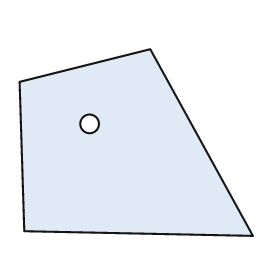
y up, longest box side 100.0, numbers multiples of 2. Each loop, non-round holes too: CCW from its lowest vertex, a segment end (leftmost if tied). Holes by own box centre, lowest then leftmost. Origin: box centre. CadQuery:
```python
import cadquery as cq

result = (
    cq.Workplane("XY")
    .moveTo(50.0, -40.0)
    .lineTo(6.0, 40.0)
    .lineTo(-50.0, 26.0)
    .lineTo(-48.0, -38.0)
    .close()
    .moveTo(-20.0, 8.0)
    .circle(4.0)
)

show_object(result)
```